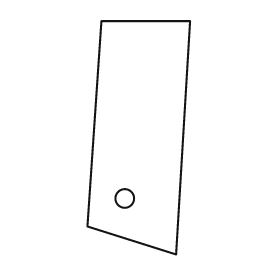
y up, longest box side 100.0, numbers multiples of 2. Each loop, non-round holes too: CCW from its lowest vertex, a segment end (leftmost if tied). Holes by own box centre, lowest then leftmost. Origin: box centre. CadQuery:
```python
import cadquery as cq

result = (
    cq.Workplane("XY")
    .moveTo(16.0, -50.0)
    .lineTo(22.0, 50.0)
    .lineTo(-16.0, 50.0)
    .lineTo(-22.0, -38.0)
    .close()
    .moveTo(-6.0, -26.0)
    .circle(4.0)
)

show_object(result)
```